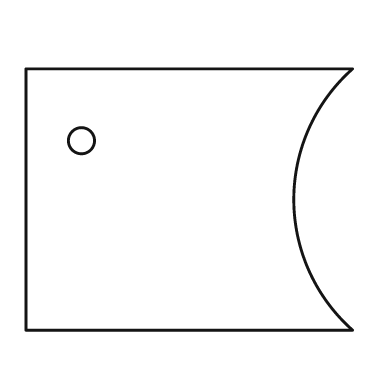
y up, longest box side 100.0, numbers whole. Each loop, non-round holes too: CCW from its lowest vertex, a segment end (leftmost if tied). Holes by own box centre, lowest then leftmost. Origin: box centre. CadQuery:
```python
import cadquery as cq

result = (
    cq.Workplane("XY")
    .moveTo(-50.0, -40.0)
    .lineTo(50.0, -40.0)
    .threePointArc((32.0, 0.0), (50.0, 40.0))
    .lineTo(-50.0, 40.0)
    .close()
    .moveTo(-33.0, 18.0)
    .circle(4.0)
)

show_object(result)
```